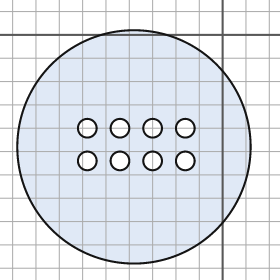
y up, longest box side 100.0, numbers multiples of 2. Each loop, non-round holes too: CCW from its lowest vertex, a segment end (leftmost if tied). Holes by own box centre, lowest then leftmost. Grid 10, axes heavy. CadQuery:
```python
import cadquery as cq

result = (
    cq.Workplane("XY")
    .moveTo(-38.0, -48.0)
    .circle(50.0)
    .moveTo(-58.0, -54.0)
    .circle(4.0)
    .moveTo(-44.0, -54.0)
    .circle(4.0)
    .moveTo(-30.0, -54.0)
    .circle(4.0)
    .moveTo(-16.0, -54.0)
    .circle(4.0)
    .moveTo(-58.0, -40.0)
    .circle(4.0)
    .moveTo(-44.0, -40.0)
    .circle(4.0)
    .moveTo(-30.0, -40.0)
    .circle(4.0)
    .moveTo(-16.0, -40.0)
    .circle(4.0)
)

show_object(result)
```